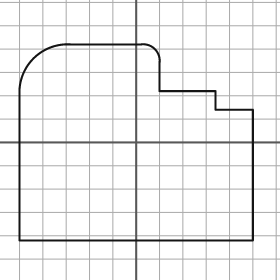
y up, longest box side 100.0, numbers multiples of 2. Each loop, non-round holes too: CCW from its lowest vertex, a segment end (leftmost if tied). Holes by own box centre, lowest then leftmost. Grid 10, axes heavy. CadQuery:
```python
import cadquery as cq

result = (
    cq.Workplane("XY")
    .moveTo(-50.0, -42.0)
    .lineTo(50.0, -42.0)
    .lineTo(50.0, 14.0)
    .lineTo(34.0, 14.0)
    .lineTo(34.0, 22.0)
    .lineTo(10.0, 22.0)
    .lineTo(10.0, 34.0)
    .threePointArc((8.0, 40.0), (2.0, 42.0))
    .lineTo(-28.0, 42.0)
    .threePointArc((-44.0, 36.0), (-50.0, 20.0))
    .close()
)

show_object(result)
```